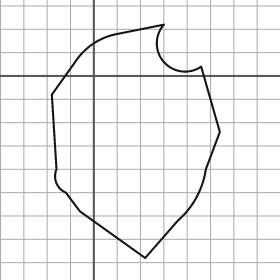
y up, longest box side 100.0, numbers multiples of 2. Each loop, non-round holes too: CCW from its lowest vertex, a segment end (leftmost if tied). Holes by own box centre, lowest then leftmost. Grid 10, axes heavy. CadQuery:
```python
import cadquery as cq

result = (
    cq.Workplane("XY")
    .moveTo(22.0, -78.0)
    .lineTo(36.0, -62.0)
    .threePointArc((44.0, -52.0), (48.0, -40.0))
    .lineTo(54.0, -24.0)
    .lineTo(46.0, 4.0)
    .threePointArc((30.0, 6.0), (30.0, 22.0))
    .lineTo(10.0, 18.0)
    .threePointArc((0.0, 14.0), (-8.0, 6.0))
    .lineTo(-18.0, -8.0)
    .lineTo(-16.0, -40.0)
    .threePointArc((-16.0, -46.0), (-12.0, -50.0))
    .lineTo(-6.0, -58.0)
    .close()
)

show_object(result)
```